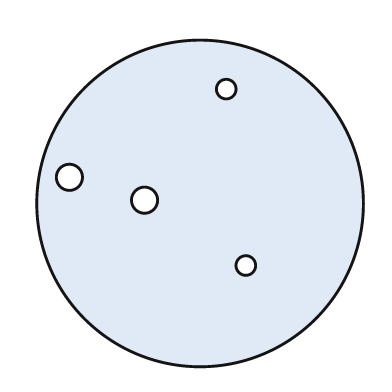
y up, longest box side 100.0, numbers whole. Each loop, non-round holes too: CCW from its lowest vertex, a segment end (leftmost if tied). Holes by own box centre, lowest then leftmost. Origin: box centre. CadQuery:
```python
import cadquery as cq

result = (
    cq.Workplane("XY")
    .moveTo(0.0, 0.0)
    .circle(50.0)
    .moveTo(14.0, -19.0)
    .circle(3.0)
    .moveTo(-17.0, 1.0)
    .circle(4.0)
    .moveTo(-40.0, 8.0)
    .circle(4.0)
    .moveTo(8.0, 35.0)
    .circle(3.0)
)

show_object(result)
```